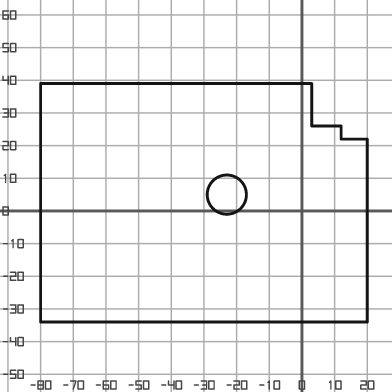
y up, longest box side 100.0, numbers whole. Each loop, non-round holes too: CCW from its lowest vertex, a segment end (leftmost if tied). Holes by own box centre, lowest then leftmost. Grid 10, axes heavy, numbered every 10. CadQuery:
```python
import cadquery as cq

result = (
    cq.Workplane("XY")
    .moveTo(-80.0, -34.0)
    .lineTo(20.0, -34.0)
    .lineTo(20.0, 22.0)
    .lineTo(12.0, 22.0)
    .lineTo(12.0, 26.0)
    .lineTo(3.0, 26.0)
    .lineTo(3.0, 39.0)
    .lineTo(-80.0, 39.0)
    .close()
    .moveTo(-23.0, 5.0)
    .circle(6.0)
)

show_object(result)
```